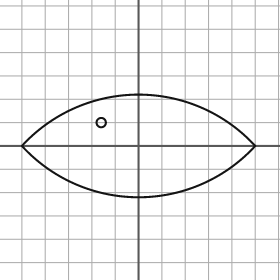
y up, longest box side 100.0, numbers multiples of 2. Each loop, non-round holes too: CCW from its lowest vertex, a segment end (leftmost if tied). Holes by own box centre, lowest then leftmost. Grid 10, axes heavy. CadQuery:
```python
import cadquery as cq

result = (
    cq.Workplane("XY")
    .moveTo(-50.0, 0.0)
    .threePointArc((0.0, -22.0), (50.0, 0.0))
    .threePointArc((0.0, 22.0), (-50.0, 0.0))
    .close()
    .moveTo(-16.0, 10.0)
    .circle(2.0)
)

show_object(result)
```